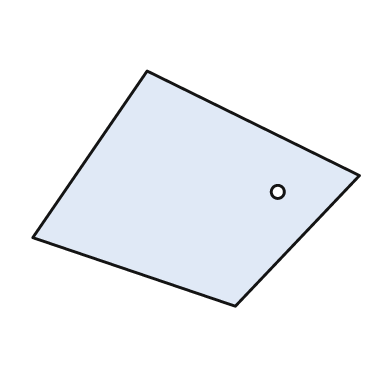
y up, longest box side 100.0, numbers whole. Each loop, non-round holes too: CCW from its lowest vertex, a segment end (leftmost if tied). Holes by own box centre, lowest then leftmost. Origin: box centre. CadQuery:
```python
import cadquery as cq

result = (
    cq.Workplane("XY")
    .moveTo(12.0, -36.0)
    .lineTo(50.0, 4.0)
    .lineTo(-15.0, 36.0)
    .lineTo(-50.0, -15.0)
    .close()
    .moveTo(25.0, -1.0)
    .circle(2.0)
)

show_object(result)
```